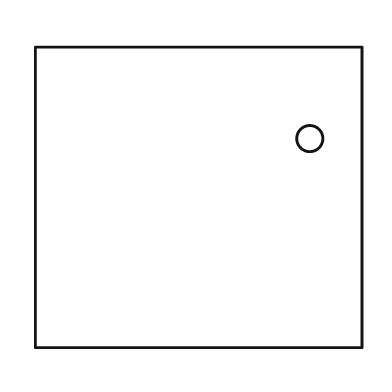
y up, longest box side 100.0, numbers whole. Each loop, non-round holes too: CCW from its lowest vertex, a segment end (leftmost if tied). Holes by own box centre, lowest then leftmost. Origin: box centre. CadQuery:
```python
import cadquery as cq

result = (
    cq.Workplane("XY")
    .moveTo(-50.0, -46.0)
    .lineTo(50.0, -46.0)
    .lineTo(50.0, 46.0)
    .lineTo(-50.0, 46.0)
    .close()
    .moveTo(34.0, 18.0)
    .circle(4.0)
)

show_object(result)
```